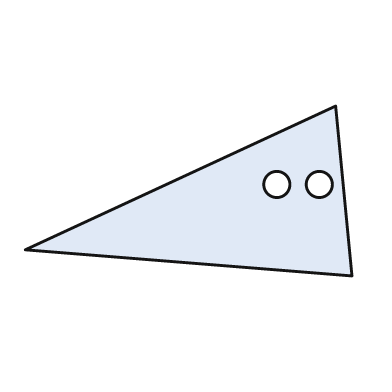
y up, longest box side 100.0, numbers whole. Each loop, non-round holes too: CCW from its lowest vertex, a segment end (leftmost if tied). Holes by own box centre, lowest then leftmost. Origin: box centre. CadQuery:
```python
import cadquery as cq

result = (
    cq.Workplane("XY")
    .moveTo(50.0, -26.0)
    .lineTo(45.0, 26.0)
    .lineTo(-50.0, -18.0)
    .close()
    .moveTo(27.0, 2.0)
    .circle(4.0)
    .moveTo(40.0, 2.0)
    .circle(4.0)
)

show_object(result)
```